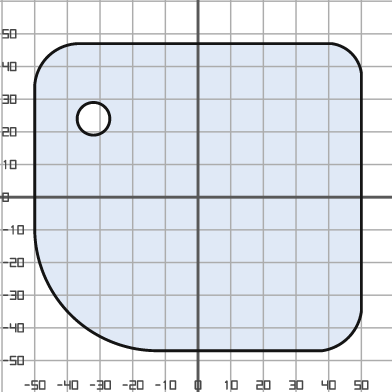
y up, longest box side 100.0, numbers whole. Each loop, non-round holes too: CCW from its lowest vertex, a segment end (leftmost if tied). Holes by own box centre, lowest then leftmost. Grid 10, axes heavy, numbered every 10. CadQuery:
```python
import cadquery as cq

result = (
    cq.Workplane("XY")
    .moveTo(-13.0, -47.0)
    .lineTo(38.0, -47.0)
    .threePointArc((46.0, -43.0), (50.0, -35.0))
    .lineTo(50.0, 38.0)
    .threePointArc((47.0, 44.0), (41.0, 47.0))
    .lineTo(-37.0, 47.0)
    .threePointArc((-46.0, 43.0), (-50.0, 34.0))
    .lineTo(-50.0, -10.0)
    .threePointArc((-39.0, -36.0), (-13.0, -47.0))
    .close()
    .moveTo(-32.0, 24.0)
    .circle(5.0)
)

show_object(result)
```